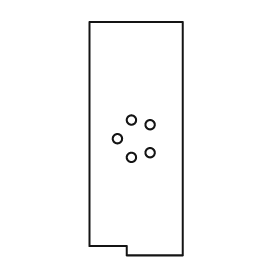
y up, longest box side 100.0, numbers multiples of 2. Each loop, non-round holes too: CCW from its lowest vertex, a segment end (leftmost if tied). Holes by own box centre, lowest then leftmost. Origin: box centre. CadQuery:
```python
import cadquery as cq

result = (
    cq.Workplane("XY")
    .moveTo(-4.0, -50.0)
    .lineTo(20.0, -50.0)
    .lineTo(20.0, 50.0)
    .lineTo(-20.0, 50.0)
    .lineTo(-20.0, -46.0)
    .lineTo(-4.0, -46.0)
    .close()
    .moveTo(-2.0, -8.0)
    .circle(2.0)
    .moveTo(6.0, -6.0)
    .circle(2.0)
    .moveTo(-8.0, 0.0)
    .circle(2.0)
    .moveTo(6.0, 6.0)
    .circle(2.0)
    .moveTo(-2.0, 8.0)
    .circle(2.0)
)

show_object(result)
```